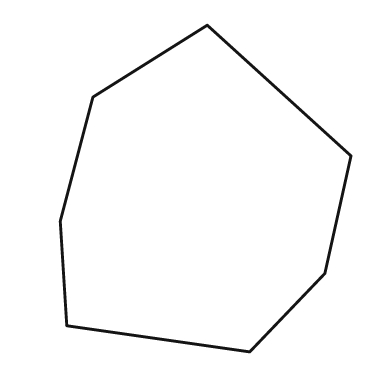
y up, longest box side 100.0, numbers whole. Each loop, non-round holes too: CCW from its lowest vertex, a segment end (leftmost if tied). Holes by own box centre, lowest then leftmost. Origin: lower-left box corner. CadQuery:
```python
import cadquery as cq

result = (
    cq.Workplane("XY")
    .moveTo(58.0, 0.0)
    .lineTo(81.0, 24.0)
    .lineTo(89.0, 60.0)
    .lineTo(45.0, 100.0)
    .lineTo(10.0, 78.0)
    .lineTo(0.0, 40.0)
    .lineTo(2.0, 8.0)
    .close()
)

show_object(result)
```